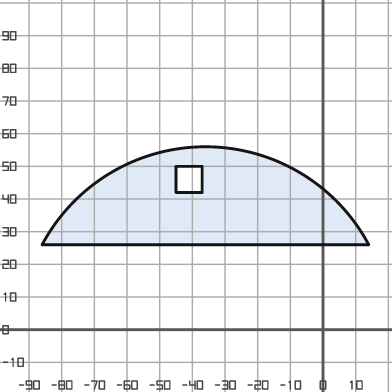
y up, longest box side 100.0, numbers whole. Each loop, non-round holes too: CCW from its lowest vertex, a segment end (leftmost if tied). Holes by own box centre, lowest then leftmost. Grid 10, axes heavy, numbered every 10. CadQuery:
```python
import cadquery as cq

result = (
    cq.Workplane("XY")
    .moveTo(-86.0, 26.0)
    .lineTo(14.0, 26.0)
    .threePointArc((-36.0, 56.0), (-86.0, 26.0))
    .close()
    .moveTo(-45.0, 42.0)
    .lineTo(-37.0, 42.0)
    .lineTo(-37.0, 50.0)
    .lineTo(-45.0, 50.0)
    .close()
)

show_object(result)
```